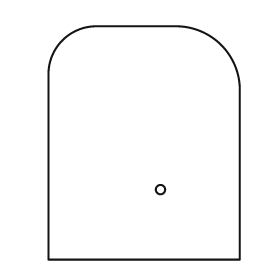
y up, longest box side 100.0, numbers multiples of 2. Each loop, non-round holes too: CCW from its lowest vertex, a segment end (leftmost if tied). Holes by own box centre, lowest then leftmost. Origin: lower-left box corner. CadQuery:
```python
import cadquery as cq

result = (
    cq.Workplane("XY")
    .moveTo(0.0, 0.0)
    .lineTo(82.0, 0.0)
    .lineTo(82.0, 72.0)
    .threePointArc((74.0, 92.0), (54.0, 100.0))
    .lineTo(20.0, 100.0)
    .threePointArc((6.0, 94.0), (0.0, 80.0))
    .close()
    .moveTo(48.0, 30.0)
    .circle(2.0)
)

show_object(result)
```